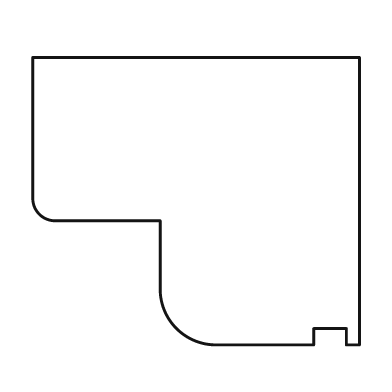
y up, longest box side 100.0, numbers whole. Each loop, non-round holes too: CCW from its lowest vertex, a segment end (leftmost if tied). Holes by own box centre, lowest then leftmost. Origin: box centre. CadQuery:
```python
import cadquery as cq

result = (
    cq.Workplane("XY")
    .moveTo(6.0, -44.0)
    .lineTo(36.0, -44.0)
    .lineTo(36.0, -39.0)
    .lineTo(46.0, -39.0)
    .lineTo(46.0, -44.0)
    .lineTo(50.0, -44.0)
    .lineTo(50.0, 44.0)
    .lineTo(-50.0, 44.0)
    .lineTo(-50.0, 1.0)
    .threePointArc((-48.0, -4.0), (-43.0, -6.0))
    .lineTo(-11.0, -6.0)
    .lineTo(-11.0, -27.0)
    .threePointArc((-6.0, -39.0), (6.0, -44.0))
    .close()
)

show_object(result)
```